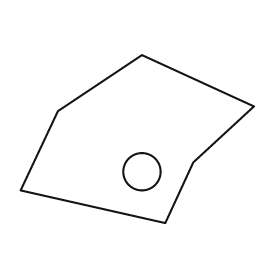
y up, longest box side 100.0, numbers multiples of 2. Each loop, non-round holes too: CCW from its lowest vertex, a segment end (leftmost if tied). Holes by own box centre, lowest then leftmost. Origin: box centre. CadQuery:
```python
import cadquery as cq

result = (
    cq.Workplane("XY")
    .moveTo(12.0, -36.0)
    .lineTo(24.0, -10.0)
    .lineTo(50.0, 14.0)
    .lineTo(2.0, 36.0)
    .lineTo(-34.0, 12.0)
    .lineTo(-50.0, -22.0)
    .close()
    .moveTo(2.0, -14.0)
    .circle(8.0)
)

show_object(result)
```